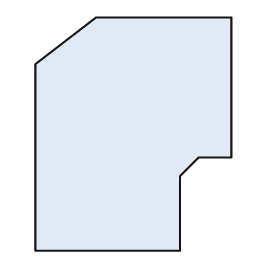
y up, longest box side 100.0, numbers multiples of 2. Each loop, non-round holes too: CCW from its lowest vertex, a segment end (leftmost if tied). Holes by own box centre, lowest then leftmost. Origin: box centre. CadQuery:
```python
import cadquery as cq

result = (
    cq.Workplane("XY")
    .moveTo(-42.0, -50.0)
    .lineTo(20.0, -50.0)
    .lineTo(20.0, -18.0)
    .lineTo(28.0, -10.0)
    .lineTo(42.0, -10.0)
    .lineTo(42.0, 50.0)
    .lineTo(-16.0, 50.0)
    .lineTo(-42.0, 30.0)
    .close()
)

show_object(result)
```